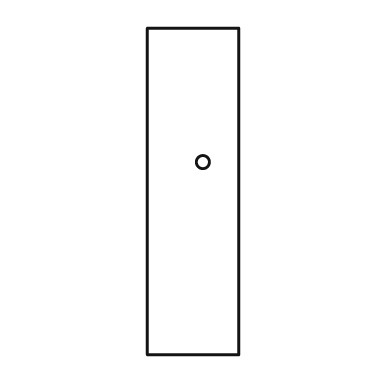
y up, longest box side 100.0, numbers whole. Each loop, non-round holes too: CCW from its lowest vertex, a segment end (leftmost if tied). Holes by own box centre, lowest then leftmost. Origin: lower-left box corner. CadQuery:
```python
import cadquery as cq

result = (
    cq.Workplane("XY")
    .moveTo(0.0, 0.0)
    .lineTo(28.0, 0.0)
    .lineTo(28.0, 100.0)
    .lineTo(0.0, 100.0)
    .close()
    .moveTo(17.0, 59.0)
    .circle(2.0)
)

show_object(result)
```